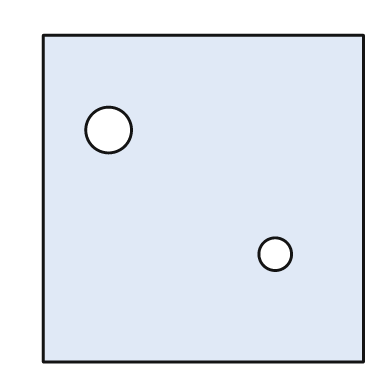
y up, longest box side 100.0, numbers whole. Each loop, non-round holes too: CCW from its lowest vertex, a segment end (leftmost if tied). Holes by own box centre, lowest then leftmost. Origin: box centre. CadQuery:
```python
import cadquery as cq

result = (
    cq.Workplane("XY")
    .moveTo(-49.0, -50.0)
    .lineTo(49.0, -50.0)
    .lineTo(49.0, 50.0)
    .lineTo(-49.0, 50.0)
    .close()
    .moveTo(22.0, -17.0)
    .circle(5.0)
    .moveTo(-29.0, 21.0)
    .circle(7.0)
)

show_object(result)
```